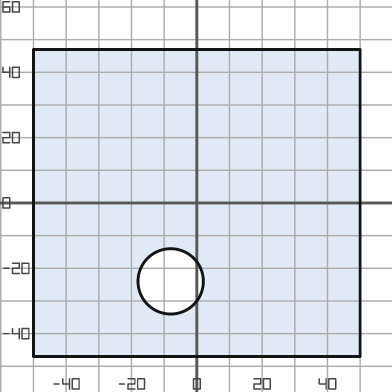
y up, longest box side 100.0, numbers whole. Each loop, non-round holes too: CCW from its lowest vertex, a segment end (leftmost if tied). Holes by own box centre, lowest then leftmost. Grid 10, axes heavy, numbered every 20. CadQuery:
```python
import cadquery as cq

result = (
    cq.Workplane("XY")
    .moveTo(-50.0, -47.0)
    .lineTo(50.0, -47.0)
    .lineTo(50.0, 47.0)
    .lineTo(-50.0, 47.0)
    .close()
    .moveTo(-8.0, -24.0)
    .circle(10.0)
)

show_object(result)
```